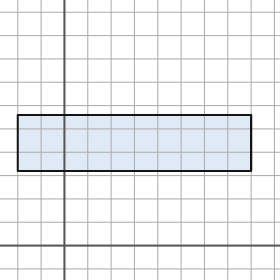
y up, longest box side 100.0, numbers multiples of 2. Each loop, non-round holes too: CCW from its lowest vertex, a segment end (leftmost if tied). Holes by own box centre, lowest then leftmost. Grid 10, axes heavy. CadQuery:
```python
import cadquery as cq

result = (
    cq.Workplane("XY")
    .moveTo(-20.0, 32.0)
    .lineTo(80.0, 32.0)
    .lineTo(80.0, 56.0)
    .lineTo(-20.0, 56.0)
    .close()
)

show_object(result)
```